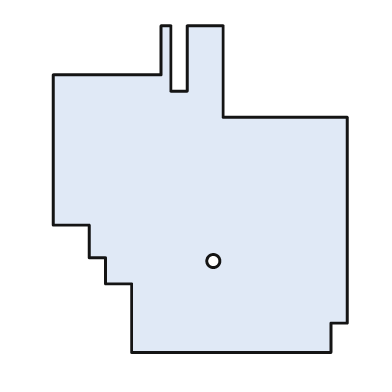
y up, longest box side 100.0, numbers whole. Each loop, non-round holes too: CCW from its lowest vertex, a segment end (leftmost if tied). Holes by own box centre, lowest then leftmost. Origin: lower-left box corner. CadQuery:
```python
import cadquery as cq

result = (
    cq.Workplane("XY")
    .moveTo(24.0, 0.0)
    .lineTo(85.0, 0.0)
    .lineTo(85.0, 9.0)
    .lineTo(90.0, 9.0)
    .lineTo(90.0, 72.0)
    .lineTo(52.0, 72.0)
    .lineTo(52.0, 100.0)
    .lineTo(41.0, 100.0)
    .lineTo(41.0, 80.0)
    .lineTo(36.0, 80.0)
    .lineTo(36.0, 100.0)
    .lineTo(33.0, 100.0)
    .lineTo(33.0, 85.0)
    .lineTo(0.0, 85.0)
    .lineTo(0.0, 39.0)
    .lineTo(11.0, 39.0)
    .lineTo(11.0, 29.0)
    .lineTo(16.0, 29.0)
    .lineTo(16.0, 21.0)
    .lineTo(24.0, 21.0)
    .close()
    .moveTo(49.0, 28.0)
    .circle(2.0)
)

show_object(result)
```